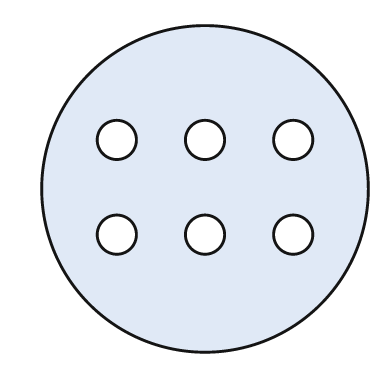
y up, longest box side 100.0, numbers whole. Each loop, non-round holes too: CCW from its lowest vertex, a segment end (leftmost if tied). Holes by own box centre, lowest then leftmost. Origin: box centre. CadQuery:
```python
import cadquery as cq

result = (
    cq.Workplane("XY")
    .moveTo(0.0, 0.0)
    .circle(50.0)
    .moveTo(-27.0, -14.0)
    .circle(6.0)
    .moveTo(0.0, -14.0)
    .circle(6.0)
    .moveTo(27.0, -14.0)
    .circle(6.0)
    .moveTo(-27.0, 15.0)
    .circle(6.0)
    .moveTo(0.0, 15.0)
    .circle(6.0)
    .moveTo(27.0, 15.0)
    .circle(6.0)
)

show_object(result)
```